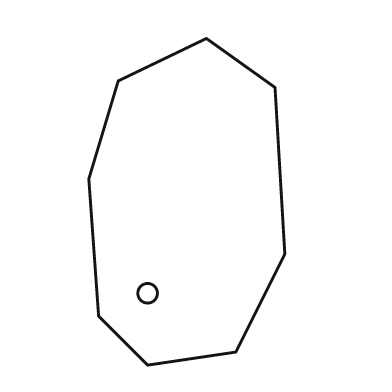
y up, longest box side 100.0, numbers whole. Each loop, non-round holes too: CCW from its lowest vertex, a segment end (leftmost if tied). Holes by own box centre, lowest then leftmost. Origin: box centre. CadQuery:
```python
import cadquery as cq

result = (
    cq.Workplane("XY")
    .moveTo(-12.0, -50.0)
    .lineTo(15.0, -46.0)
    .lineTo(30.0, -16.0)
    .lineTo(27.0, 35.0)
    .lineTo(6.0, 50.0)
    .lineTo(-21.0, 37.0)
    .lineTo(-30.0, 7.0)
    .lineTo(-27.0, -35.0)
    .close()
    .moveTo(-12.0, -28.0)
    .circle(3.0)
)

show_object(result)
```